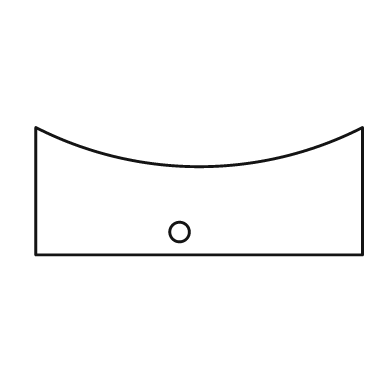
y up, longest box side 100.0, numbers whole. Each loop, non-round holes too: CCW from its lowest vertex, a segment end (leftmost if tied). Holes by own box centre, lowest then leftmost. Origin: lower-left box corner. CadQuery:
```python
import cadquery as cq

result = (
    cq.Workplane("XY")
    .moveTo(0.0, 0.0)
    .lineTo(100.0, 0.0)
    .lineTo(100.0, 39.0)
    .threePointArc((50.0, 27.0), (0.0, 39.0))
    .close()
    .moveTo(44.0, 7.0)
    .circle(3.0)
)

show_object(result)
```